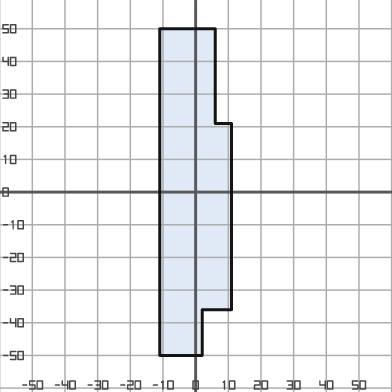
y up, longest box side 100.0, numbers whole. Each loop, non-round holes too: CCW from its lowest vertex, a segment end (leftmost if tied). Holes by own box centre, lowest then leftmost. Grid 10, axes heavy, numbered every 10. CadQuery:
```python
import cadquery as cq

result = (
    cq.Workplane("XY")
    .moveTo(-11.0, -50.0)
    .lineTo(2.0, -50.0)
    .lineTo(2.0, -36.0)
    .lineTo(11.0, -36.0)
    .lineTo(11.0, 21.0)
    .lineTo(6.0, 21.0)
    .lineTo(6.0, 50.0)
    .lineTo(-11.0, 50.0)
    .close()
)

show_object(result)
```